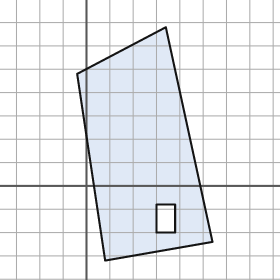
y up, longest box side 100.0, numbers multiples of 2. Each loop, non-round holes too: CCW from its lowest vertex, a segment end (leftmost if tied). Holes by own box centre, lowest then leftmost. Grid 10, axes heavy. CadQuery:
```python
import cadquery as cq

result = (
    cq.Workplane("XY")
    .moveTo(8.0, -32.0)
    .lineTo(54.0, -24.0)
    .lineTo(34.0, 68.0)
    .lineTo(-4.0, 48.0)
    .close()
    .moveTo(30.0, -20.0)
    .lineTo(38.0, -20.0)
    .lineTo(38.0, -8.0)
    .lineTo(30.0, -8.0)
    .close()
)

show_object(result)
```